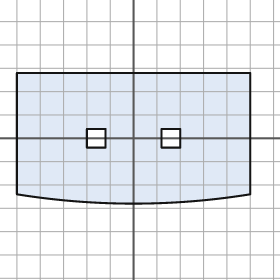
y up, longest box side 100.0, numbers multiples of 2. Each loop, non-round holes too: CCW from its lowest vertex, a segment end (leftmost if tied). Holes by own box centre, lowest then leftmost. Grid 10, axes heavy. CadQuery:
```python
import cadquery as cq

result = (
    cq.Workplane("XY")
    .moveTo(-50.0, -24.0)
    .threePointArc((0.0, -28.0), (50.0, -24.0))
    .lineTo(50.0, 28.0)
    .lineTo(-50.0, 28.0)
    .close()
    .moveTo(-20.0, -4.0)
    .lineTo(-12.0, -4.0)
    .lineTo(-12.0, 4.0)
    .lineTo(-20.0, 4.0)
    .close()
    .moveTo(12.0, -4.0)
    .lineTo(20.0, -4.0)
    .lineTo(20.0, 4.0)
    .lineTo(12.0, 4.0)
    .close()
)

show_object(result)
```